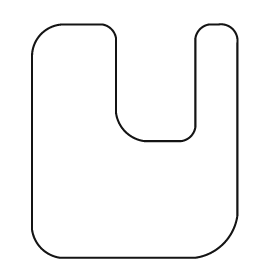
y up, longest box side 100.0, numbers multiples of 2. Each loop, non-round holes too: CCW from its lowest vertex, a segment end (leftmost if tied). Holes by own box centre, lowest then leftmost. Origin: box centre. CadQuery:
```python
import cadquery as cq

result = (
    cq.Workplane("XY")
    .moveTo(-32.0, -50.0)
    .lineTo(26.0, -50.0)
    .threePointArc((38.0, -44.0), (44.0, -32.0))
    .lineTo(44.0, 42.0)
    .threePointArc((42.0, 48.0), (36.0, 50.0))
    .lineTo(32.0, 50.0)
    .threePointArc((28.0, 48.0), (26.0, 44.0))
    .lineTo(26.0, 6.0)
    .threePointArc((24.0, 2.0), (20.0, 0.0))
    .lineTo(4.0, 0.0)
    .threePointArc((-4.0, 4.0), (-8.0, 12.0))
    .lineTo(-8.0, 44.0)
    .threePointArc((-10.0, 48.0), (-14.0, 50.0))
    .lineTo(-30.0, 50.0)
    .threePointArc((-40.0, 46.0), (-44.0, 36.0))
    .lineTo(-44.0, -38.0)
    .threePointArc((-40.0, -46.0), (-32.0, -50.0))
    .close()
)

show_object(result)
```